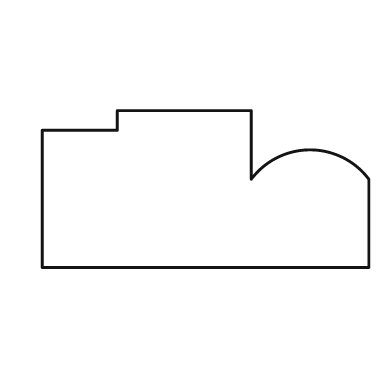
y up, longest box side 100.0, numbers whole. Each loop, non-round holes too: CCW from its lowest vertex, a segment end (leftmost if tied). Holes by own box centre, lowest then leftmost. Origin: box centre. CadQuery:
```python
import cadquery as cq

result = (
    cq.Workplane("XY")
    .moveTo(-50.0, -24.0)
    .lineTo(50.0, -24.0)
    .lineTo(50.0, 3.0)
    .threePointArc((32.0, 12.0), (14.0, 3.0))
    .lineTo(14.0, 24.0)
    .lineTo(-27.0, 24.0)
    .lineTo(-27.0, 18.0)
    .lineTo(-50.0, 18.0)
    .close()
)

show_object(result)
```